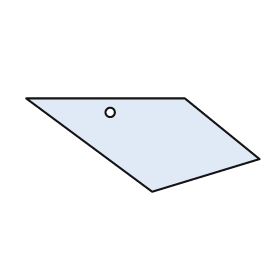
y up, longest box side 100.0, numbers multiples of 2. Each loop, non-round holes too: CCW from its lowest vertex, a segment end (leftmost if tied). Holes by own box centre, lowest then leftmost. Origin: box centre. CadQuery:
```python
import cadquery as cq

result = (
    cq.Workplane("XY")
    .moveTo(4.0, -20.0)
    .lineTo(50.0, -6.0)
    .lineTo(18.0, 20.0)
    .lineTo(-50.0, 20.0)
    .close()
    .moveTo(-14.0, 14.0)
    .circle(2.0)
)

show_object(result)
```